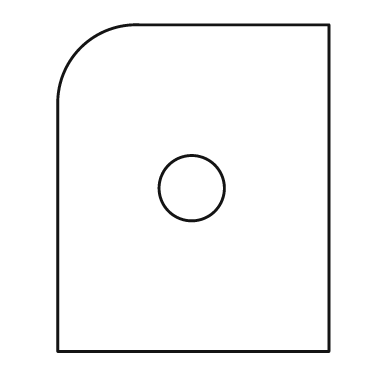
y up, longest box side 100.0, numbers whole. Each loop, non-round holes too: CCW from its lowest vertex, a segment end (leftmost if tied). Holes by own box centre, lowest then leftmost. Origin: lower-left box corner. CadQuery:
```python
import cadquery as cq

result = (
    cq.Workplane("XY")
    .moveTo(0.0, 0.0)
    .lineTo(83.0, 0.0)
    .lineTo(83.0, 100.0)
    .lineTo(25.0, 100.0)
    .threePointArc((7.0, 93.0), (0.0, 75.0))
    .close()
    .moveTo(41.0, 50.0)
    .circle(10.0)
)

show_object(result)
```